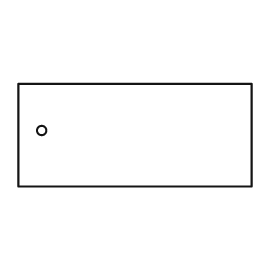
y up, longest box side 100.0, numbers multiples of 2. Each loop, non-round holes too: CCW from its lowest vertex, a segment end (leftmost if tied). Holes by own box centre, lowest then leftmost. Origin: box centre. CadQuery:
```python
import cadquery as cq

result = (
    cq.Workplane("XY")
    .moveTo(-50.0, -22.0)
    .lineTo(50.0, -22.0)
    .lineTo(50.0, 22.0)
    .lineTo(-50.0, 22.0)
    .close()
    .moveTo(-40.0, 2.0)
    .circle(2.0)
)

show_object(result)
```